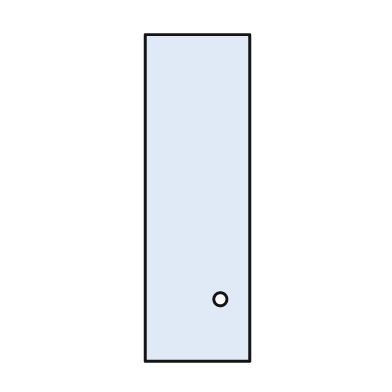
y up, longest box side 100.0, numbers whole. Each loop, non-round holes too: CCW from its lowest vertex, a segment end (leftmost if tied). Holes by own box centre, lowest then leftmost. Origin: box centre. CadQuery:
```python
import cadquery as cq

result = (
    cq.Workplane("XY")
    .moveTo(-16.0, -50.0)
    .lineTo(16.0, -50.0)
    .lineTo(16.0, 50.0)
    .lineTo(-16.0, 50.0)
    .close()
    .moveTo(7.0, -31.0)
    .circle(2.0)
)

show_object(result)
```